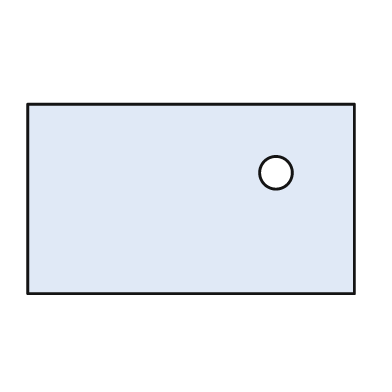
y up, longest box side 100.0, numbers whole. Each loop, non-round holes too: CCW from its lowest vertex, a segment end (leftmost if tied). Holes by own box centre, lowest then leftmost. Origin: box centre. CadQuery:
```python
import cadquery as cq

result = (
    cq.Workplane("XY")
    .moveTo(-50.0, -29.0)
    .lineTo(50.0, -29.0)
    .lineTo(50.0, 29.0)
    .lineTo(-50.0, 29.0)
    .close()
    .moveTo(26.0, 8.0)
    .circle(5.0)
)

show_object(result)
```